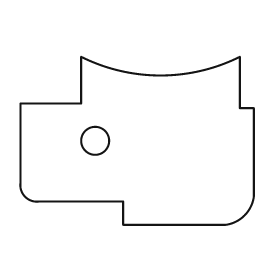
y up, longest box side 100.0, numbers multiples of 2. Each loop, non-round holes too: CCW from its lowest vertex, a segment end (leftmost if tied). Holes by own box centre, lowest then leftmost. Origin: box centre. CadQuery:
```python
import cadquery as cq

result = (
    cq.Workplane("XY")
    .moveTo(-6.0, -36.0)
    .lineTo(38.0, -36.0)
    .threePointArc((46.0, -32.0), (50.0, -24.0))
    .lineTo(50.0, 14.0)
    .lineTo(44.0, 14.0)
    .lineTo(44.0, 36.0)
    .threePointArc((10.0, 28.0), (-24.0, 36.0))
    .lineTo(-24.0, 16.0)
    .lineTo(-50.0, 16.0)
    .lineTo(-50.0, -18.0)
    .threePointArc((-48.0, -24.0), (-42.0, -26.0))
    .lineTo(-6.0, -26.0)
    .close()
    .moveTo(-18.0, 0.0)
    .circle(6.0)
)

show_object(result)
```